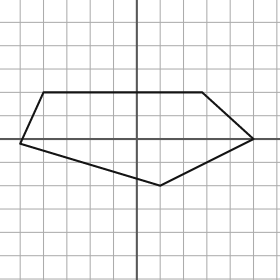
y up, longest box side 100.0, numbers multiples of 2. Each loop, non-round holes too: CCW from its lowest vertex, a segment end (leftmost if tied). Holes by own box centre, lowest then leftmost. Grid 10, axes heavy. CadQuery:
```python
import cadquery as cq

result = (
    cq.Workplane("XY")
    .moveTo(10.0, -20.0)
    .lineTo(50.0, 0.0)
    .lineTo(28.0, 20.0)
    .lineTo(-40.0, 20.0)
    .lineTo(-50.0, -2.0)
    .close()
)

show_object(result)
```